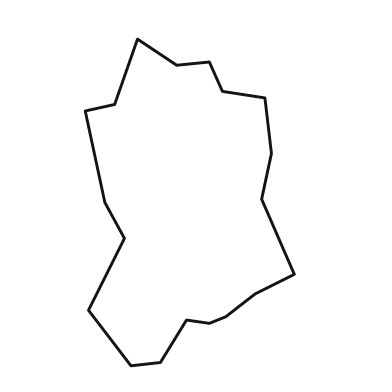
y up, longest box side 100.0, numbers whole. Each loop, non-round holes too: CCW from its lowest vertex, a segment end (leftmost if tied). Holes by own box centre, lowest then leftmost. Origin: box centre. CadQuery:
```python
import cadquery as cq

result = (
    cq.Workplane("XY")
    .moveTo(-18.0, -50.0)
    .lineTo(-9.0, -49.0)
    .lineTo(-1.0, -36.0)
    .lineTo(6.0, -37.0)
    .lineTo(11.0, -35.0)
    .lineTo(20.0, -28.0)
    .lineTo(32.0, -22.0)
    .lineTo(22.0, 1.0)
    .lineTo(25.0, 15.0)
    .lineTo(23.0, 32.0)
    .lineTo(10.0, 34.0)
    .lineTo(6.0, 43.0)
    .lineTo(-4.0, 42.0)
    .lineTo(-16.0, 50.0)
    .lineTo(-23.0, 30.0)
    .lineTo(-32.0, 28.0)
    .lineTo(-26.0, 0.0)
    .lineTo(-20.0, -11.0)
    .lineTo(-31.0, -33.0)
    .close()
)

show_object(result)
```